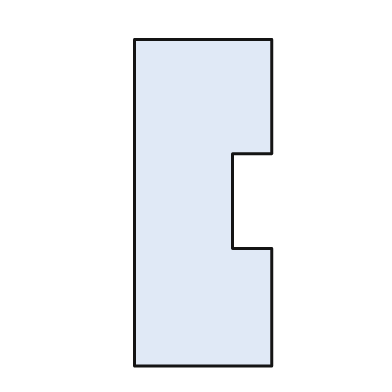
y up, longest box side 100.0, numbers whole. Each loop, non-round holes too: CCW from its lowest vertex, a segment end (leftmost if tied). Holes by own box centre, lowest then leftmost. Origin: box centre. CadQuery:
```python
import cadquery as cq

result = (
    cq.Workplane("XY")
    .moveTo(-21.0, -50.0)
    .lineTo(21.0, -50.0)
    .lineTo(21.0, -14.0)
    .lineTo(9.0, -14.0)
    .lineTo(9.0, 15.0)
    .lineTo(21.0, 15.0)
    .lineTo(21.0, 50.0)
    .lineTo(-21.0, 50.0)
    .close()
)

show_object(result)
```